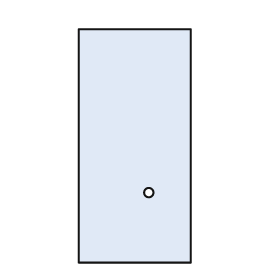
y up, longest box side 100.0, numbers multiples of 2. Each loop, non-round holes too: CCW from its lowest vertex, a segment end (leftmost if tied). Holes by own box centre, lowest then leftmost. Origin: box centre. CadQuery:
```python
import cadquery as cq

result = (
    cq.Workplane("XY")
    .moveTo(-24.0, -50.0)
    .lineTo(24.0, -50.0)
    .lineTo(24.0, 50.0)
    .lineTo(-24.0, 50.0)
    .close()
    .moveTo(6.0, -20.0)
    .circle(2.0)
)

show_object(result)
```